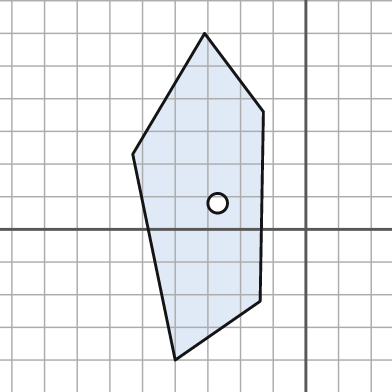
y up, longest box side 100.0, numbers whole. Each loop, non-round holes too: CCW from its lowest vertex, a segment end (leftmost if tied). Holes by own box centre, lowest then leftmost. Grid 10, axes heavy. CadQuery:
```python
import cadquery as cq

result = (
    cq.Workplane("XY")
    .moveTo(-40.0, -40.0)
    .lineTo(-14.0, -22.0)
    .lineTo(-13.0, 36.0)
    .lineTo(-31.0, 60.0)
    .lineTo(-53.0, 23.0)
    .close()
    .moveTo(-27.0, 8.0)
    .circle(3.0)
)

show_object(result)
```